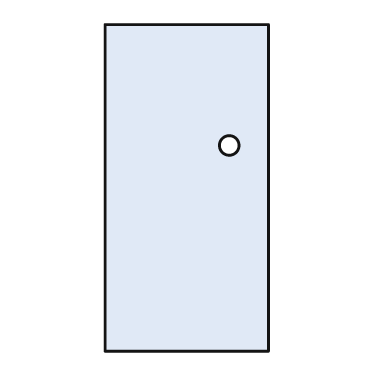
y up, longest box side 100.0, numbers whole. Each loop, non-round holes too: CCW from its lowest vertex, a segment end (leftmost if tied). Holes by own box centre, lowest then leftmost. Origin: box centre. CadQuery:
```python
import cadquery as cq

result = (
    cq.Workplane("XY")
    .moveTo(-25.0, -50.0)
    .lineTo(25.0, -50.0)
    .lineTo(25.0, 50.0)
    .lineTo(-25.0, 50.0)
    .close()
    .moveTo(13.0, 13.0)
    .circle(3.0)
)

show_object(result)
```